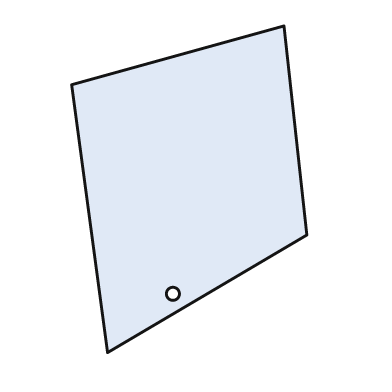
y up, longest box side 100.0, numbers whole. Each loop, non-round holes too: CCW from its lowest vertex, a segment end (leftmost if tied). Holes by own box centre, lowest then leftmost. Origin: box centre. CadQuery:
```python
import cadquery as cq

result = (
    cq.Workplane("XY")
    .moveTo(-25.0, -50.0)
    .lineTo(36.0, -14.0)
    .lineTo(29.0, 50.0)
    .lineTo(-36.0, 32.0)
    .close()
    .moveTo(-5.0, -32.0)
    .circle(2.0)
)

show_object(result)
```